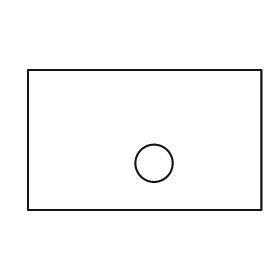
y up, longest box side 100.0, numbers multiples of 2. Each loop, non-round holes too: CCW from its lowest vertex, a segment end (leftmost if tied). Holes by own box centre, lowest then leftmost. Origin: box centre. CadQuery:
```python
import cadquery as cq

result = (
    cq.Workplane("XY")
    .moveTo(-50.0, -30.0)
    .lineTo(50.0, -30.0)
    .lineTo(50.0, 30.0)
    .lineTo(-50.0, 30.0)
    .close()
    .moveTo(4.0, -10.0)
    .circle(8.0)
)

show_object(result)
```